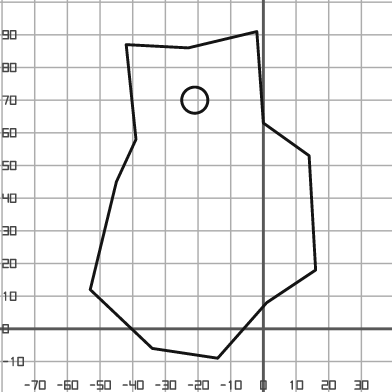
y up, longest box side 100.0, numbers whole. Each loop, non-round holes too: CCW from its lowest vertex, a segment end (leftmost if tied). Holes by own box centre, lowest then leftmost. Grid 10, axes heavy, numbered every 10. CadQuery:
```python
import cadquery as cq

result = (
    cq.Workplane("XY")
    .moveTo(-14.0, -9.0)
    .lineTo(1.0, 8.0)
    .lineTo(16.0, 18.0)
    .lineTo(14.0, 53.0)
    .lineTo(0.0, 63.0)
    .lineTo(-2.0, 91.0)
    .lineTo(-23.0, 86.0)
    .lineTo(-42.0, 87.0)
    .lineTo(-39.0, 58.0)
    .lineTo(-45.0, 45.0)
    .lineTo(-53.0, 12.0)
    .lineTo(-34.0, -6.0)
    .close()
    .moveTo(-21.0, 70.0)
    .circle(4.0)
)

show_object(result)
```